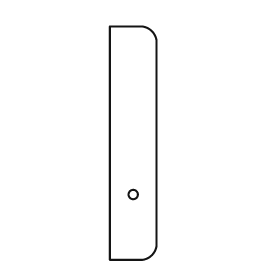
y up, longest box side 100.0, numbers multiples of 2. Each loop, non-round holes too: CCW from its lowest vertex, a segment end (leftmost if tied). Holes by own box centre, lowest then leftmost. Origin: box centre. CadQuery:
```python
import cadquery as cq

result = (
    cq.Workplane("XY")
    .moveTo(-10.0, -50.0)
    .lineTo(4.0, -50.0)
    .threePointArc((8.0, -48.0), (10.0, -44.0))
    .lineTo(10.0, 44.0)
    .threePointArc((8.0, 48.0), (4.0, 50.0))
    .lineTo(-10.0, 50.0)
    .close()
    .moveTo(0.0, -22.0)
    .circle(2.0)
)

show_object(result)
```